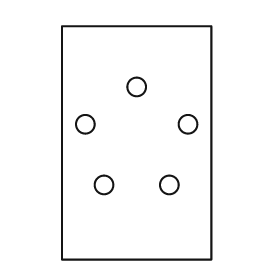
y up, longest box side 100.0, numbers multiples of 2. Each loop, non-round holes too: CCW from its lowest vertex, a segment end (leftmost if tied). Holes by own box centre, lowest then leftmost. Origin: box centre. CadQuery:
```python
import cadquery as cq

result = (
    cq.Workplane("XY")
    .moveTo(-32.0, -50.0)
    .lineTo(32.0, -50.0)
    .lineTo(32.0, 50.0)
    .lineTo(-32.0, 50.0)
    .close()
    .moveTo(-14.0, -18.0)
    .circle(4.0)
    .moveTo(14.0, -18.0)
    .circle(4.0)
    .moveTo(-22.0, 8.0)
    .circle(4.0)
    .moveTo(22.0, 8.0)
    .circle(4.0)
    .moveTo(0.0, 24.0)
    .circle(4.0)
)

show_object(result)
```